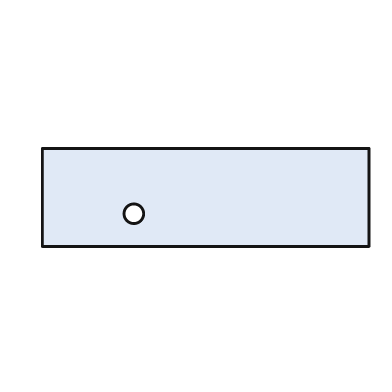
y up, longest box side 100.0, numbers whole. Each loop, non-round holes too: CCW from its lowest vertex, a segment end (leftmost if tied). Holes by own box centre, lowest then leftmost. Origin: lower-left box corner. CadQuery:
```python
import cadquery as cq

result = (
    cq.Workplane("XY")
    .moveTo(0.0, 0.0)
    .lineTo(100.0, 0.0)
    .lineTo(100.0, 30.0)
    .lineTo(0.0, 30.0)
    .close()
    .moveTo(28.0, 10.0)
    .circle(3.0)
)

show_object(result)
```